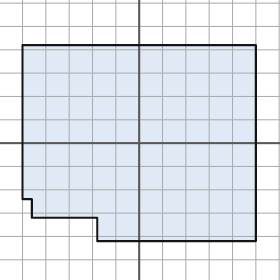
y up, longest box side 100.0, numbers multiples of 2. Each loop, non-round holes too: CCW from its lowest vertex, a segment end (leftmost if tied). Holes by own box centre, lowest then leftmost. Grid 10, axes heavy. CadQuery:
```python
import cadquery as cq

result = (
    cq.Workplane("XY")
    .moveTo(-18.0, -42.0)
    .lineTo(50.0, -42.0)
    .lineTo(50.0, 42.0)
    .lineTo(-50.0, 42.0)
    .lineTo(-50.0, -24.0)
    .lineTo(-46.0, -24.0)
    .lineTo(-46.0, -32.0)
    .lineTo(-18.0, -32.0)
    .close()
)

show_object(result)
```